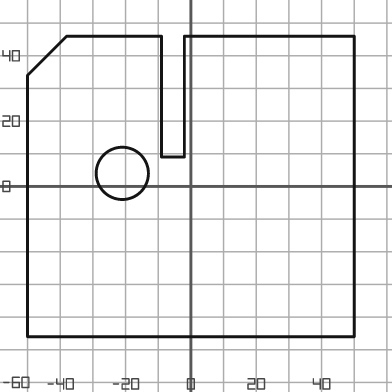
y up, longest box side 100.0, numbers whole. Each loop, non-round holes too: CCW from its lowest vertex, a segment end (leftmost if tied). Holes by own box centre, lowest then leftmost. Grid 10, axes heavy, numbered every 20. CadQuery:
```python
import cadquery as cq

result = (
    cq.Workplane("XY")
    .moveTo(-50.0, -46.0)
    .lineTo(50.0, -46.0)
    .lineTo(50.0, 46.0)
    .lineTo(-2.0, 46.0)
    .lineTo(-2.0, 9.0)
    .lineTo(-9.0, 9.0)
    .lineTo(-9.0, 46.0)
    .lineTo(-38.0, 46.0)
    .lineTo(-50.0, 34.0)
    .close()
    .moveTo(-21.0, 4.0)
    .circle(8.0)
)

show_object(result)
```